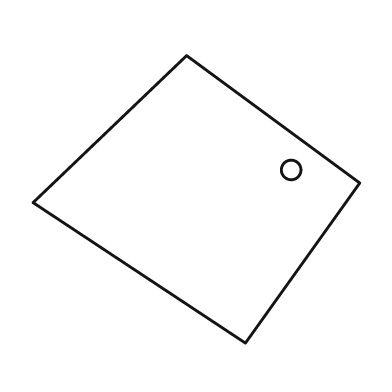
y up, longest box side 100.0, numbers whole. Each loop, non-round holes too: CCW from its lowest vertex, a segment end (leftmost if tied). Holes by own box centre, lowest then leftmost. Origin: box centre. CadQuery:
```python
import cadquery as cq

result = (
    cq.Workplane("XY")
    .moveTo(15.0, -44.0)
    .lineTo(50.0, 5.0)
    .lineTo(-3.0, 44.0)
    .lineTo(-50.0, -1.0)
    .close()
    .moveTo(29.0, 9.0)
    .circle(3.0)
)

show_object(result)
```